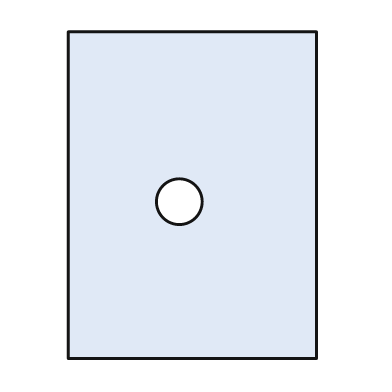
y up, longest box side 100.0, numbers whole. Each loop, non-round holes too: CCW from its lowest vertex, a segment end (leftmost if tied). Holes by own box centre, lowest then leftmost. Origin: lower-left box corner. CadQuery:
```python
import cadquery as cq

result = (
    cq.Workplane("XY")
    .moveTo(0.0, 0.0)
    .lineTo(76.0, 0.0)
    .lineTo(76.0, 100.0)
    .lineTo(0.0, 100.0)
    .close()
    .moveTo(34.0, 48.0)
    .circle(7.0)
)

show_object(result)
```